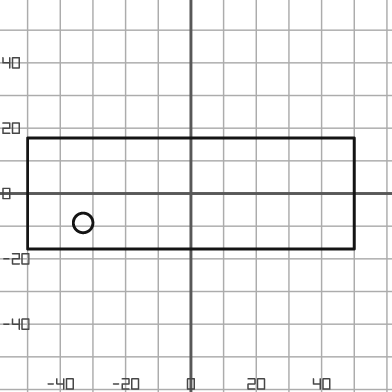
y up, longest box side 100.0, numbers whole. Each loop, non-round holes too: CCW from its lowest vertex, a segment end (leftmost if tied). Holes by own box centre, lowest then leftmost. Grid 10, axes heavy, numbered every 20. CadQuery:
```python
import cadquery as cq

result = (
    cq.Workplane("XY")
    .moveTo(-50.0, -17.0)
    .lineTo(50.0, -17.0)
    .lineTo(50.0, 17.0)
    .lineTo(-50.0, 17.0)
    .close()
    .moveTo(-33.0, -9.0)
    .circle(3.0)
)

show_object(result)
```